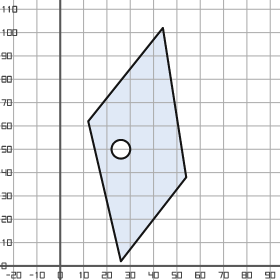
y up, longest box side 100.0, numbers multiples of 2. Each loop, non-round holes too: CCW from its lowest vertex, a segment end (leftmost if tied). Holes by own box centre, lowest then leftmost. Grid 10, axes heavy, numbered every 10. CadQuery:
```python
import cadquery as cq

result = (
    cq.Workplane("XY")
    .moveTo(26.0, 2.0)
    .lineTo(54.0, 38.0)
    .lineTo(44.0, 102.0)
    .lineTo(12.0, 62.0)
    .close()
    .moveTo(26.0, 50.0)
    .circle(4.0)
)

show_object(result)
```